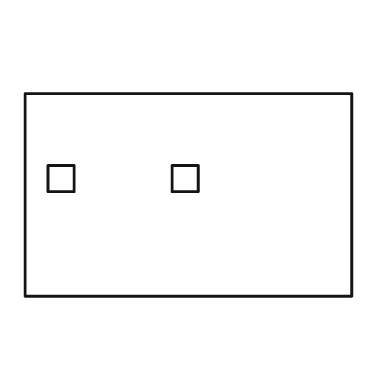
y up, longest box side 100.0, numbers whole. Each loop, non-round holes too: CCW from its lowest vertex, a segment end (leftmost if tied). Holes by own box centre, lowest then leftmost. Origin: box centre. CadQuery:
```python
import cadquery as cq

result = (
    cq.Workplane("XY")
    .moveTo(-50.0, -31.0)
    .lineTo(50.0, -31.0)
    .lineTo(50.0, 31.0)
    .lineTo(-50.0, 31.0)
    .close()
    .moveTo(-43.0, 1.0)
    .lineTo(-35.0, 1.0)
    .lineTo(-35.0, 9.0)
    .lineTo(-43.0, 9.0)
    .close()
    .moveTo(-5.0, 1.0)
    .lineTo(3.0, 1.0)
    .lineTo(3.0, 9.0)
    .lineTo(-5.0, 9.0)
    .close()
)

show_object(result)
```